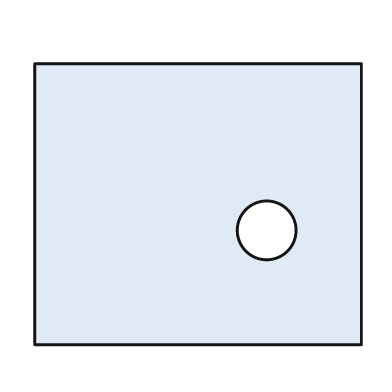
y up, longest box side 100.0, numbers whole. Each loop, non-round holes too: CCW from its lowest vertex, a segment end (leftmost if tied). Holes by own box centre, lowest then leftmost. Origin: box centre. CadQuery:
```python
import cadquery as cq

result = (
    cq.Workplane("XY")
    .moveTo(-50.0, -43.0)
    .lineTo(50.0, -43.0)
    .lineTo(50.0, 43.0)
    .lineTo(-50.0, 43.0)
    .close()
    .moveTo(21.0, -8.0)
    .circle(9.0)
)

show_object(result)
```